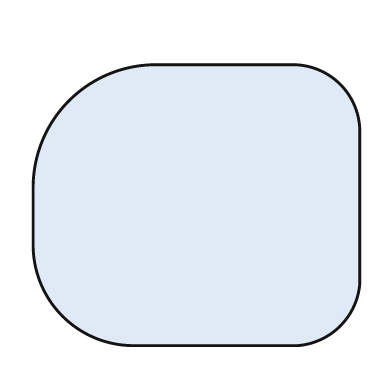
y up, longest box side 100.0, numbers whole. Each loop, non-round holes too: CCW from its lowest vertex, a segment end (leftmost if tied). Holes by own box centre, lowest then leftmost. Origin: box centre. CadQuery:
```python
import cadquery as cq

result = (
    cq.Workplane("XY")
    .moveTo(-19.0, -43.0)
    .lineTo(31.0, -43.0)
    .threePointArc((44.0, -37.0), (50.0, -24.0))
    .lineTo(50.0, 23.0)
    .threePointArc((44.0, 37.0), (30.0, 43.0))
    .lineTo(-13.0, 43.0)
    .threePointArc((-39.0, 32.0), (-50.0, 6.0))
    .lineTo(-50.0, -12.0)
    .threePointArc((-41.0, -34.0), (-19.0, -43.0))
    .close()
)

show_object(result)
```